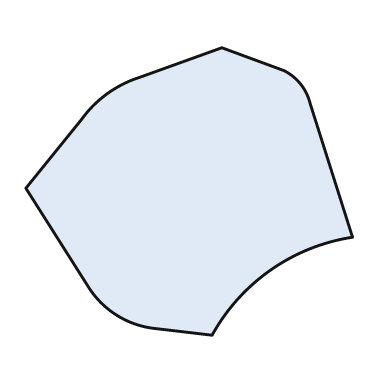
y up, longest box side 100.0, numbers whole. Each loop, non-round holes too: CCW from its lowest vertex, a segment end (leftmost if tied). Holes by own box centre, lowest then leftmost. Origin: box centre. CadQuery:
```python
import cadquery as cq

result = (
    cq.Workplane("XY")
    .moveTo(7.0, -44.0)
    .threePointArc((25.0, -24.0), (50.0, -14.0))
    .lineTo(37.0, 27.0)
    .threePointArc((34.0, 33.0), (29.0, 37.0))
    .lineTo(10.0, 44.0)
    .lineTo(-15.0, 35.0)
    .threePointArc((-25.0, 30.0), (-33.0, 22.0))
    .lineTo(-50.0, 1.0)
    .lineTo(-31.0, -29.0)
    .threePointArc((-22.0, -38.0), (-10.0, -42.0))
    .close()
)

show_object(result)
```